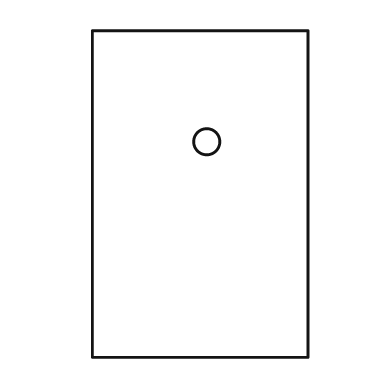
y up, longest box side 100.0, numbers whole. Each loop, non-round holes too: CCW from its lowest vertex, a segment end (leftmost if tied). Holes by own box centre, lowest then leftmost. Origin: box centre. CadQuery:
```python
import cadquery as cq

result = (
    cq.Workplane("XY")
    .moveTo(-33.0, -50.0)
    .lineTo(33.0, -50.0)
    .lineTo(33.0, 50.0)
    .lineTo(-33.0, 50.0)
    .close()
    .moveTo(2.0, 16.0)
    .circle(4.0)
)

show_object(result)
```